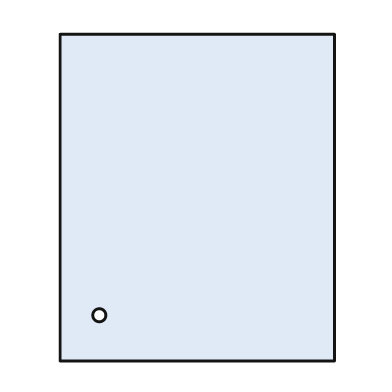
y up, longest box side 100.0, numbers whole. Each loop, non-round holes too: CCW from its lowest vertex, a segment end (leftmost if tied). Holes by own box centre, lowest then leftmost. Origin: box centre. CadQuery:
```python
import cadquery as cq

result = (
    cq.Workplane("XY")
    .moveTo(-42.0, -50.0)
    .lineTo(42.0, -50.0)
    .lineTo(42.0, 50.0)
    .lineTo(-42.0, 50.0)
    .close()
    .moveTo(-30.0, -36.0)
    .circle(2.0)
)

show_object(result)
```